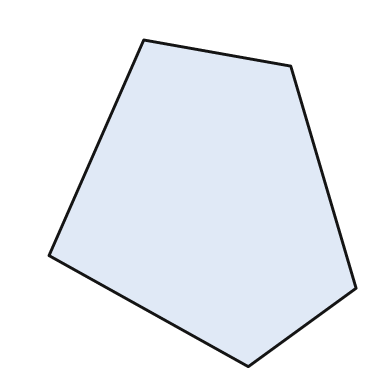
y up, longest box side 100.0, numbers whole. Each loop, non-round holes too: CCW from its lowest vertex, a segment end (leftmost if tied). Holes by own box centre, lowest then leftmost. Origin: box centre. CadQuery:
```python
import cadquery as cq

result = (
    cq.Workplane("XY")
    .moveTo(14.0, -50.0)
    .lineTo(47.0, -26.0)
    .lineTo(27.0, 42.0)
    .lineTo(-18.0, 50.0)
    .lineTo(-47.0, -16.0)
    .close()
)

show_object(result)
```